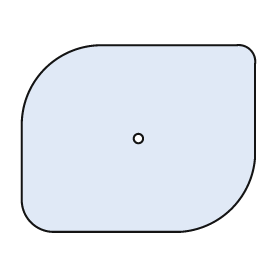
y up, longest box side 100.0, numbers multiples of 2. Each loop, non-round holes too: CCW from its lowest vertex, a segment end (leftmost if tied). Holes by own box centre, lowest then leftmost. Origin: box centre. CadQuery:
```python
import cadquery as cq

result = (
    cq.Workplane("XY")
    .moveTo(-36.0, -40.0)
    .lineTo(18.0, -40.0)
    .threePointArc((40.0, -30.0), (50.0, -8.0))
    .lineTo(50.0, 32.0)
    .threePointArc((48.0, 38.0), (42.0, 40.0))
    .lineTo(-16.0, 40.0)
    .threePointArc((-40.0, 30.0), (-50.0, 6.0))
    .lineTo(-50.0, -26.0)
    .threePointArc((-46.0, -36.0), (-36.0, -40.0))
    .close()
    .moveTo(0.0, 0.0)
    .circle(2.0)
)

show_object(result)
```